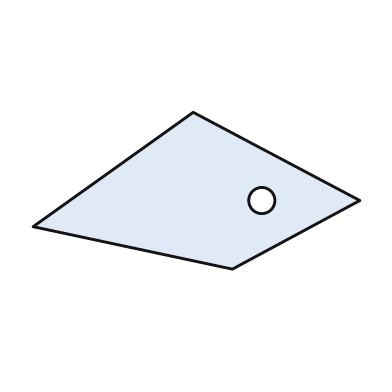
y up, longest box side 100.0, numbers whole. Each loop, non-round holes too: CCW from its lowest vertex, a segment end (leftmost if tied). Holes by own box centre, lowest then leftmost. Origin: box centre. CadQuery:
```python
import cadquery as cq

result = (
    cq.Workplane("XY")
    .moveTo(11.0, -24.0)
    .lineTo(50.0, -3.0)
    .lineTo(-1.0, 24.0)
    .lineTo(-50.0, -11.0)
    .close()
    .moveTo(20.0, -3.0)
    .circle(4.0)
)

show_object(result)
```